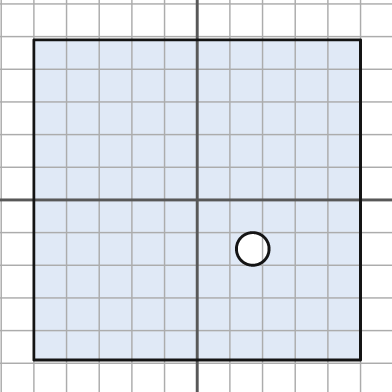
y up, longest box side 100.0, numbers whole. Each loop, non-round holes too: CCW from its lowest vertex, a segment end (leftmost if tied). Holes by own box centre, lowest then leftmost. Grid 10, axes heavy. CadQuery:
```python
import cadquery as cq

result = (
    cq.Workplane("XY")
    .moveTo(-50.0, -49.0)
    .lineTo(50.0, -49.0)
    .lineTo(50.0, 49.0)
    .lineTo(-50.0, 49.0)
    .close()
    .moveTo(17.0, -15.0)
    .circle(5.0)
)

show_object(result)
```